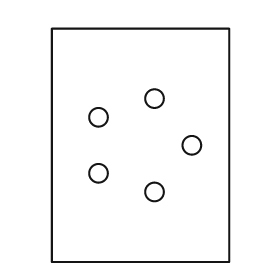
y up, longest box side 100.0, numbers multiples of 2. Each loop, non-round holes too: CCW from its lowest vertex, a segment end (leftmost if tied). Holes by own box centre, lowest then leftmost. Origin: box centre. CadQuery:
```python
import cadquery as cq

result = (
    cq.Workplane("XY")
    .moveTo(-38.0, -50.0)
    .lineTo(38.0, -50.0)
    .lineTo(38.0, 50.0)
    .lineTo(-38.0, 50.0)
    .close()
    .moveTo(6.0, -20.0)
    .circle(4.0)
    .moveTo(-18.0, -12.0)
    .circle(4.0)
    .moveTo(22.0, 0.0)
    .circle(4.0)
    .moveTo(-18.0, 12.0)
    .circle(4.0)
    .moveTo(6.0, 20.0)
    .circle(4.0)
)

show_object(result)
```